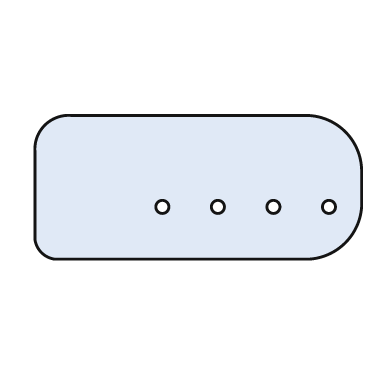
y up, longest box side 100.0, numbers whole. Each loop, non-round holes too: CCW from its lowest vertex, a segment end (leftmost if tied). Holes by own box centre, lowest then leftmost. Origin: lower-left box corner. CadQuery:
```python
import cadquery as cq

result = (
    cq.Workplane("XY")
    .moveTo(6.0, 0.0)
    .lineTo(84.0, 0.0)
    .threePointArc((95.0, 5.0), (100.0, 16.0))
    .lineTo(100.0, 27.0)
    .threePointArc((95.0, 39.0), (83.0, 44.0))
    .lineTo(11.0, 44.0)
    .threePointArc((3.0, 41.0), (0.0, 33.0))
    .lineTo(0.0, 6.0)
    .threePointArc((2.0, 2.0), (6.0, 0.0))
    .close()
    .moveTo(39.0, 16.0)
    .circle(2.0)
    .moveTo(56.0, 16.0)
    .circle(2.0)
    .moveTo(73.0, 16.0)
    .circle(2.0)
    .moveTo(90.0, 16.0)
    .circle(2.0)
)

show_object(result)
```